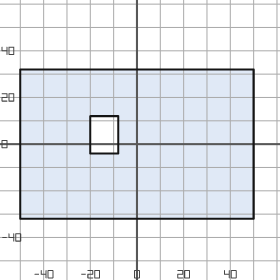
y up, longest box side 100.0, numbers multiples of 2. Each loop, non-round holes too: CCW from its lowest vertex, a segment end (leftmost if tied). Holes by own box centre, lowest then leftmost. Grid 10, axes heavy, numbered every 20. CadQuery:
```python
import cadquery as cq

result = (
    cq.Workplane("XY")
    .moveTo(-50.0, -32.0)
    .lineTo(50.0, -32.0)
    .lineTo(50.0, 32.0)
    .lineTo(-50.0, 32.0)
    .close()
    .moveTo(-20.0, -4.0)
    .lineTo(-8.0, -4.0)
    .lineTo(-8.0, 12.0)
    .lineTo(-20.0, 12.0)
    .close()
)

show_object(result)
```